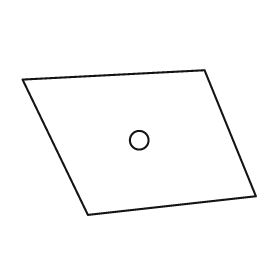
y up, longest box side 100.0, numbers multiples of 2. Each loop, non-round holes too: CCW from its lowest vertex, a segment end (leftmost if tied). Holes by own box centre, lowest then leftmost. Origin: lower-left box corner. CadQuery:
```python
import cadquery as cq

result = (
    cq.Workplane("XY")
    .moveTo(28.0, 0.0)
    .lineTo(100.0, 8.0)
    .lineTo(78.0, 62.0)
    .lineTo(0.0, 58.0)
    .close()
    .moveTo(50.0, 32.0)
    .circle(4.0)
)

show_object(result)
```